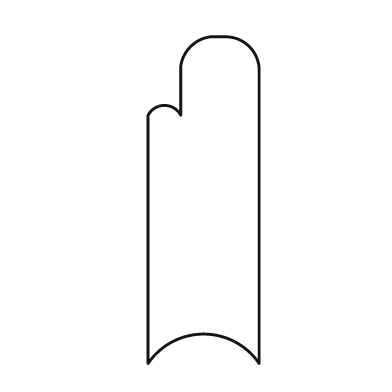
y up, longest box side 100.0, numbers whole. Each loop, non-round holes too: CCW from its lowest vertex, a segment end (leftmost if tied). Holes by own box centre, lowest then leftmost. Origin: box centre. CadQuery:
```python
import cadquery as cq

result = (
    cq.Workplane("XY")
    .moveTo(-17.0, -50.0)
    .threePointArc((0.0, -41.0), (17.0, -50.0))
    .lineTo(17.0, 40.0)
    .threePointArc((14.0, 47.0), (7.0, 50.0))
    .lineTo(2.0, 50.0)
    .threePointArc((-4.0, 47.0), (-7.0, 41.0))
    .lineTo(-7.0, 26.0)
    .threePointArc((-12.0, 29.0), (-17.0, 26.0))
    .close()
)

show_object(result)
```